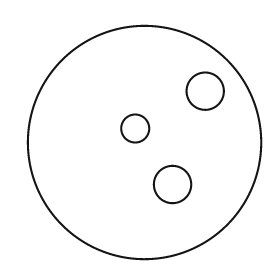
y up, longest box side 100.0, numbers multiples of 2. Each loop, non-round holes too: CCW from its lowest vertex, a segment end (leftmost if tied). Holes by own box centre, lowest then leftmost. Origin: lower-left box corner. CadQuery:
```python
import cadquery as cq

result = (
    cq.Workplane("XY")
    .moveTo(50.0, 50.0)
    .circle(50.0)
    .moveTo(62.0, 32.0)
    .circle(8.0)
    .moveTo(46.0, 56.0)
    .circle(6.0)
    .moveTo(76.0, 72.0)
    .circle(8.0)
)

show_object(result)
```